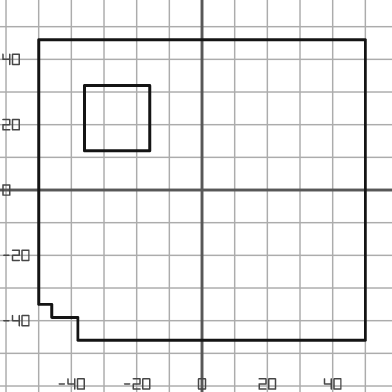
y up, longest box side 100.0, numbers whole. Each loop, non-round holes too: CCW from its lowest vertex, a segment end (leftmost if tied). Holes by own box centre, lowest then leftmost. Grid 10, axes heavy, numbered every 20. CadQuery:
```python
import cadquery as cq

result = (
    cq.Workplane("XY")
    .moveTo(-38.0, -46.0)
    .lineTo(50.0, -46.0)
    .lineTo(50.0, 46.0)
    .lineTo(-50.0, 46.0)
    .lineTo(-50.0, -35.0)
    .lineTo(-46.0, -35.0)
    .lineTo(-46.0, -39.0)
    .lineTo(-38.0, -39.0)
    .close()
    .moveTo(-36.0, 12.0)
    .lineTo(-16.0, 12.0)
    .lineTo(-16.0, 32.0)
    .lineTo(-36.0, 32.0)
    .close()
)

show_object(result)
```